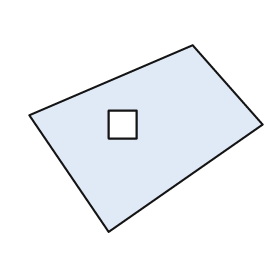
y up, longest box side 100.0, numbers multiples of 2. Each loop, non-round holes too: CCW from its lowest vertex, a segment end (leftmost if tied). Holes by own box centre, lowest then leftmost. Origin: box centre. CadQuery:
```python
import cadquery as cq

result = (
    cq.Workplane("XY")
    .moveTo(-16.0, -40.0)
    .lineTo(50.0, 6.0)
    .lineTo(20.0, 40.0)
    .lineTo(-50.0, 10.0)
    .close()
    .moveTo(-16.0, 0.0)
    .lineTo(-4.0, 0.0)
    .lineTo(-4.0, 12.0)
    .lineTo(-16.0, 12.0)
    .close()
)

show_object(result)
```